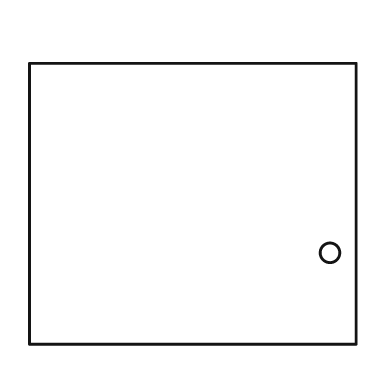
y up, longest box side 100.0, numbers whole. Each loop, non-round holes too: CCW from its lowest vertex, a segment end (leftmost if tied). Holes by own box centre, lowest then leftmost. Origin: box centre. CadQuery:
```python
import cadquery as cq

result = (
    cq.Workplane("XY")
    .moveTo(-50.0, -43.0)
    .lineTo(50.0, -43.0)
    .lineTo(50.0, 43.0)
    .lineTo(-50.0, 43.0)
    .close()
    .moveTo(42.0, -15.0)
    .circle(3.0)
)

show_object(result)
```